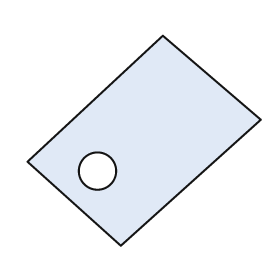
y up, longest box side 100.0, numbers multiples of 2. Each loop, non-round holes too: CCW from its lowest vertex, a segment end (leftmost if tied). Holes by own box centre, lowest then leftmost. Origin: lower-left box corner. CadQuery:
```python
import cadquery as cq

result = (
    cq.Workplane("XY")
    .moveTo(40.0, 0.0)
    .lineTo(100.0, 54.0)
    .lineTo(58.0, 90.0)
    .lineTo(0.0, 36.0)
    .close()
    .moveTo(30.0, 32.0)
    .circle(8.0)
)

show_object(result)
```